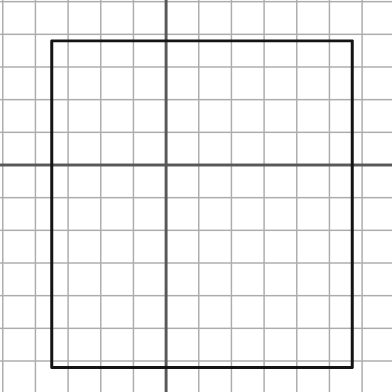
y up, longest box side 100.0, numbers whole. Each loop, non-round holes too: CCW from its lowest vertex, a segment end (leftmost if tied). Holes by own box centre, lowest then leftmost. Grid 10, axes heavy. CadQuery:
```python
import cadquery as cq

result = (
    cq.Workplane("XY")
    .moveTo(-35.0, -62.0)
    .lineTo(57.0, -62.0)
    .lineTo(57.0, 38.0)
    .lineTo(-35.0, 38.0)
    .close()
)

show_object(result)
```